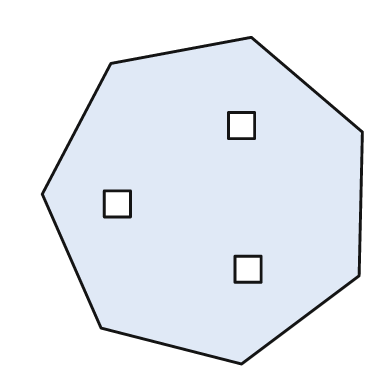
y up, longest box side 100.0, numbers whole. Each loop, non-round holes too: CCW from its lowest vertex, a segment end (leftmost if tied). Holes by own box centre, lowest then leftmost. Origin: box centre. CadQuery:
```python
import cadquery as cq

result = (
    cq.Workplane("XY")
    .moveTo(12.0, -50.0)
    .lineTo(48.0, -23.0)
    .lineTo(49.0, 21.0)
    .lineTo(15.0, 50.0)
    .lineTo(-28.0, 42.0)
    .lineTo(-49.0, 2.0)
    .lineTo(-31.0, -39.0)
    .close()
    .moveTo(10.0, -25.0)
    .lineTo(18.0, -25.0)
    .lineTo(18.0, -17.0)
    .lineTo(10.0, -17.0)
    .close()
    .moveTo(-30.0, -5.0)
    .lineTo(-22.0, -5.0)
    .lineTo(-22.0, 3.0)
    .lineTo(-30.0, 3.0)
    .close()
    .moveTo(8.0, 19.0)
    .lineTo(16.0, 19.0)
    .lineTo(16.0, 27.0)
    .lineTo(8.0, 27.0)
    .close()
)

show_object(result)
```